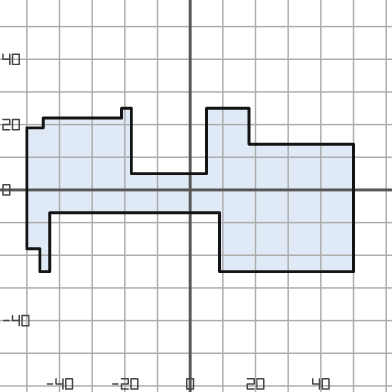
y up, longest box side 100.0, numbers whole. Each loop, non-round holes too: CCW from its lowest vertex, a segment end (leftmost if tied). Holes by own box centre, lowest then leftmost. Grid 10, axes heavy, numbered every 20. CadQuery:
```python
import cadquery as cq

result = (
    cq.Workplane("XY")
    .moveTo(-46.0, -25.0)
    .lineTo(-43.0, -25.0)
    .lineTo(-43.0, -7.0)
    .lineTo(9.0, -7.0)
    .lineTo(9.0, -25.0)
    .lineTo(50.0, -25.0)
    .lineTo(50.0, 14.0)
    .lineTo(18.0, 14.0)
    .lineTo(18.0, 25.0)
    .lineTo(5.0, 25.0)
    .lineTo(5.0, 5.0)
    .lineTo(-18.0, 5.0)
    .lineTo(-18.0, 25.0)
    .lineTo(-21.0, 25.0)
    .lineTo(-21.0, 22.0)
    .lineTo(-45.0, 22.0)
    .lineTo(-45.0, 19.0)
    .lineTo(-50.0, 19.0)
    .lineTo(-50.0, -18.0)
    .lineTo(-46.0, -18.0)
    .close()
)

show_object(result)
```